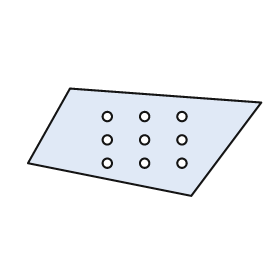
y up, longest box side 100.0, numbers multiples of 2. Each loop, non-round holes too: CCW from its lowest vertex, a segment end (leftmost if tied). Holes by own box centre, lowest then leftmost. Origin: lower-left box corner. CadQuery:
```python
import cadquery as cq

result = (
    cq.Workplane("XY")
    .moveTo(70.0, 0.0)
    .lineTo(100.0, 40.0)
    .lineTo(18.0, 46.0)
    .lineTo(0.0, 14.0)
    .close()
    .moveTo(34.0, 14.0)
    .circle(2.0)
    .moveTo(50.0, 14.0)
    .circle(2.0)
    .moveTo(66.0, 14.0)
    .circle(2.0)
    .moveTo(34.0, 24.0)
    .circle(2.0)
    .moveTo(50.0, 24.0)
    .circle(2.0)
    .moveTo(66.0, 24.0)
    .circle(2.0)
    .moveTo(34.0, 34.0)
    .circle(2.0)
    .moveTo(50.0, 34.0)
    .circle(2.0)
    .moveTo(66.0, 34.0)
    .circle(2.0)
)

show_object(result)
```